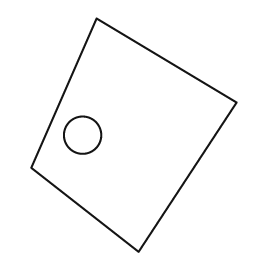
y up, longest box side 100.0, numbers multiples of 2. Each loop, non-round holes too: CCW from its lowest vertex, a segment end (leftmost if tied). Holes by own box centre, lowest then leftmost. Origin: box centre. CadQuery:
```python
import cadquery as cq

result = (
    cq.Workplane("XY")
    .moveTo(2.0, -50.0)
    .lineTo(44.0, 14.0)
    .lineTo(-16.0, 50.0)
    .lineTo(-44.0, -14.0)
    .close()
    .moveTo(-22.0, 0.0)
    .circle(8.0)
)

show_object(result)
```